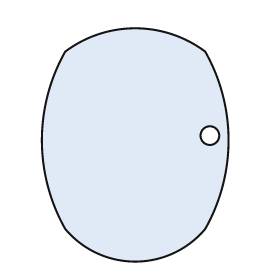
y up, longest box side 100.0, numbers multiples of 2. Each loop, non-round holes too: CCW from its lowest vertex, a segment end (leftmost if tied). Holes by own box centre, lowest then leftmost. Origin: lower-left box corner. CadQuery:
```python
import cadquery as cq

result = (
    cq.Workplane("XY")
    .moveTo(10.0, 14.0)
    .threePointArc((40.0, 0.0), (70.0, 14.0))
    .threePointArc((80.0, 52.0), (70.0, 90.0))
    .threePointArc((40.0, 100.0), (10.0, 90.0))
    .threePointArc((0.0, 52.0), (10.0, 14.0))
    .close()
    .moveTo(72.0, 54.0)
    .circle(4.0)
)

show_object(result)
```